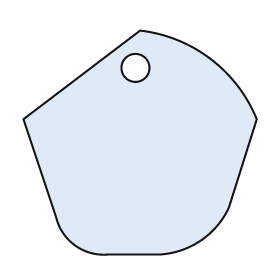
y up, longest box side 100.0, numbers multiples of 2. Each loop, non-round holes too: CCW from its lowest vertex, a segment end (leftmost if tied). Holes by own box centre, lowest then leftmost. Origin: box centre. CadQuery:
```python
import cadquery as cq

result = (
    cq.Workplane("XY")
    .moveTo(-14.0, -48.0)
    .lineTo(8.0, -48.0)
    .threePointArc((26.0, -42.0), (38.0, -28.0))
    .lineTo(50.0, 10.0)
    .threePointArc((30.0, 36.0), (0.0, 48.0))
    .lineTo(-50.0, 10.0)
    .lineTo(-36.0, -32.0)
    .threePointArc((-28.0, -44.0), (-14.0, -48.0))
    .close()
    .moveTo(-2.0, 32.0)
    .circle(6.0)
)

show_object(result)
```